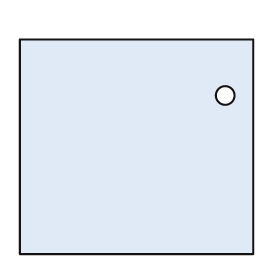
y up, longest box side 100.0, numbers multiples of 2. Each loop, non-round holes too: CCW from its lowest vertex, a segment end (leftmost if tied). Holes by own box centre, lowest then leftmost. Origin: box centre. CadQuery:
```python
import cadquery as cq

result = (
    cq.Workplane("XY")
    .moveTo(-50.0, -46.0)
    .lineTo(50.0, -46.0)
    .lineTo(50.0, 46.0)
    .lineTo(-50.0, 46.0)
    .close()
    .moveTo(38.0, 22.0)
    .circle(4.0)
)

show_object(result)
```